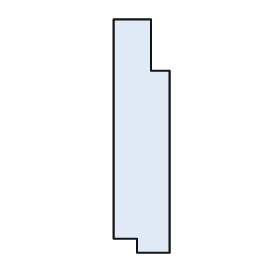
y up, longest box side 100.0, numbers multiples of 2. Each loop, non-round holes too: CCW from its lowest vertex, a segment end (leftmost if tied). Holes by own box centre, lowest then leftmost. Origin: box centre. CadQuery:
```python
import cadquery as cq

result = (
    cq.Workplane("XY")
    .moveTo(-2.0, -50.0)
    .lineTo(12.0, -50.0)
    .lineTo(12.0, 28.0)
    .lineTo(4.0, 28.0)
    .lineTo(4.0, 50.0)
    .lineTo(-12.0, 50.0)
    .lineTo(-12.0, -44.0)
    .lineTo(-2.0, -44.0)
    .close()
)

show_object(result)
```